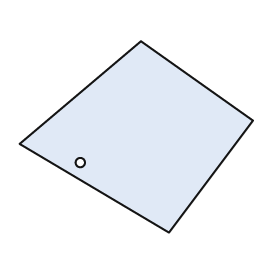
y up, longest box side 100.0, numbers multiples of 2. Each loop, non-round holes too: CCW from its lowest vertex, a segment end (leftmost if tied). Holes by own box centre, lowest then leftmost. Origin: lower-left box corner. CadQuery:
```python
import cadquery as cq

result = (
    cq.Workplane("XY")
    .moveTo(64.0, 0.0)
    .lineTo(100.0, 48.0)
    .lineTo(52.0, 82.0)
    .lineTo(0.0, 38.0)
    .close()
    .moveTo(26.0, 30.0)
    .circle(2.0)
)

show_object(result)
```